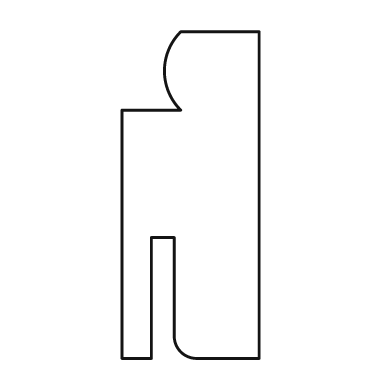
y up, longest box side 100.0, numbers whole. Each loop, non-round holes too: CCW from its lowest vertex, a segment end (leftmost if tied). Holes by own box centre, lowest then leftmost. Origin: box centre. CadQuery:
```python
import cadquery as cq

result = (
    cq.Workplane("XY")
    .moveTo(-21.0, -50.0)
    .lineTo(-12.0, -50.0)
    .lineTo(-12.0, -13.0)
    .lineTo(-5.0, -13.0)
    .lineTo(-5.0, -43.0)
    .threePointArc((-3.0, -48.0), (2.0, -50.0))
    .lineTo(21.0, -50.0)
    .lineTo(21.0, 50.0)
    .lineTo(-3.0, 50.0)
    .threePointArc((-8.0, 38.0), (-3.0, 26.0))
    .lineTo(-21.0, 26.0)
    .close()
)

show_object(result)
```